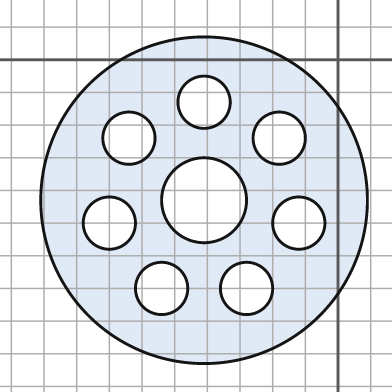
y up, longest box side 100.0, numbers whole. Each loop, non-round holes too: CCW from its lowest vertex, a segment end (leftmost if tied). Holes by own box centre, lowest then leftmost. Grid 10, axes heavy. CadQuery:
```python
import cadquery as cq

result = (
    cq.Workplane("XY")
    .moveTo(-41.0, -43.0)
    .circle(50.0)
    .moveTo(-54.0, -70.0)
    .circle(8.0)
    .moveTo(-28.0, -70.0)
    .circle(8.0)
    .moveTo(-70.0, -50.0)
    .circle(8.0)
    .moveTo(-12.0, -50.0)
    .circle(8.0)
    .moveTo(-41.0, -43.0)
    .circle(13.0)
    .moveTo(-64.0, -24.0)
    .circle(8.0)
    .moveTo(-18.0, -24.0)
    .circle(8.0)
    .moveTo(-41.0, -13.0)
    .circle(8.0)
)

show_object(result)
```